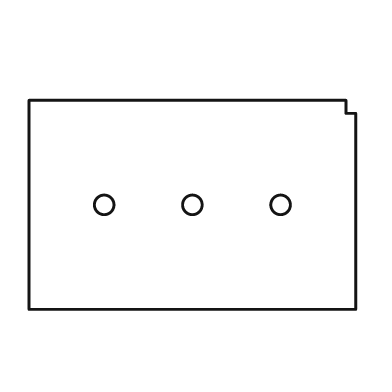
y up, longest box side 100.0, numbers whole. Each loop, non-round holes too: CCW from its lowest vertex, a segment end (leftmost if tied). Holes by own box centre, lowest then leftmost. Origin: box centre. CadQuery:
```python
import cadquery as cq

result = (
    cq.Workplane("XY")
    .moveTo(-50.0, -32.0)
    .lineTo(50.0, -32.0)
    .lineTo(50.0, 28.0)
    .lineTo(47.0, 28.0)
    .lineTo(47.0, 32.0)
    .lineTo(-50.0, 32.0)
    .close()
    .moveTo(-27.0, 0.0)
    .circle(3.0)
    .moveTo(0.0, 0.0)
    .circle(3.0)
    .moveTo(27.0, 0.0)
    .circle(3.0)
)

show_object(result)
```